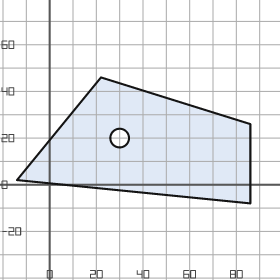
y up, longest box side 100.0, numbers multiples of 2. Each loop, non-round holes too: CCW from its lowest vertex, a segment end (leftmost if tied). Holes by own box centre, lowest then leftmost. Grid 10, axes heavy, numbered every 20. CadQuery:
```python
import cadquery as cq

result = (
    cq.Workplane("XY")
    .moveTo(86.0, -8.0)
    .lineTo(86.0, 26.0)
    .lineTo(22.0, 46.0)
    .lineTo(-14.0, 2.0)
    .close()
    .moveTo(30.0, 20.0)
    .circle(4.0)
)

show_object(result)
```